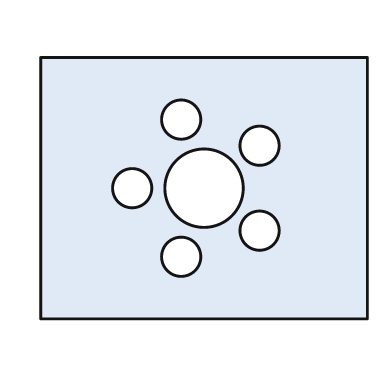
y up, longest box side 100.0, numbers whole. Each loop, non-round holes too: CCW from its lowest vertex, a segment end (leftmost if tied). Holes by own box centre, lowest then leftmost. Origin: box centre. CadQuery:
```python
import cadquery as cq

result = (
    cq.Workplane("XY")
    .moveTo(-50.0, -40.0)
    .lineTo(50.0, -40.0)
    .lineTo(50.0, 40.0)
    .lineTo(-50.0, 40.0)
    .close()
    .moveTo(-7.0, -21.0)
    .circle(6.0)
    .moveTo(17.0, -13.0)
    .circle(6.0)
    .moveTo(-22.0, 0.0)
    .circle(6.0)
    .moveTo(0.0, 0.0)
    .circle(12.0)
    .moveTo(17.0, 13.0)
    .circle(6.0)
    .moveTo(-7.0, 21.0)
    .circle(6.0)
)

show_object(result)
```